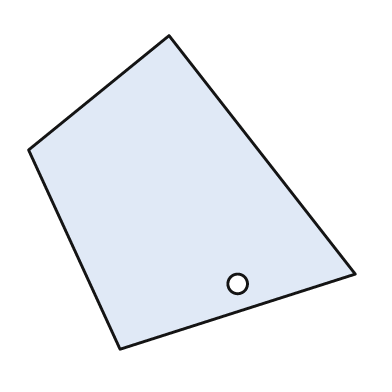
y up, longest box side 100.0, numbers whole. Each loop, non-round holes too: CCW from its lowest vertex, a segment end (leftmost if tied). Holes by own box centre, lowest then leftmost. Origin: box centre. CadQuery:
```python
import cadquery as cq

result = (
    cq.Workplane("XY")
    .moveTo(-22.0, -48.0)
    .lineTo(50.0, -25.0)
    .lineTo(-7.0, 48.0)
    .lineTo(-50.0, 13.0)
    .close()
    .moveTo(14.0, -28.0)
    .circle(3.0)
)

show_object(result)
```